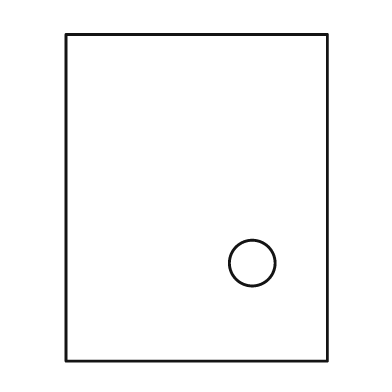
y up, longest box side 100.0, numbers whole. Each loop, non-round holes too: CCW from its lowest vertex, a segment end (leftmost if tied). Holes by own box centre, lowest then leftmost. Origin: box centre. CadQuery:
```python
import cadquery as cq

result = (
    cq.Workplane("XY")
    .moveTo(-40.0, -50.0)
    .lineTo(40.0, -50.0)
    .lineTo(40.0, 50.0)
    .lineTo(-40.0, 50.0)
    .close()
    .moveTo(17.0, -20.0)
    .circle(7.0)
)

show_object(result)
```